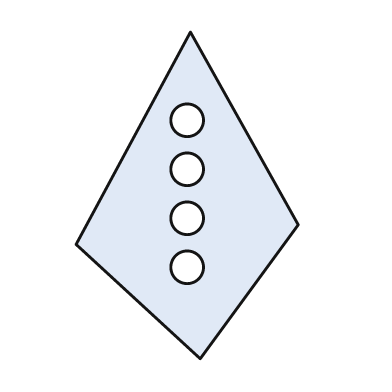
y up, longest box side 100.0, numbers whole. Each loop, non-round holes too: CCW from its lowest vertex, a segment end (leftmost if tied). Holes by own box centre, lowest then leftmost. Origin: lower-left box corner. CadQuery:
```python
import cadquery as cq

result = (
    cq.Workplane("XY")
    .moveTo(38.0, 0.0)
    .lineTo(68.0, 41.0)
    .lineTo(35.0, 100.0)
    .lineTo(0.0, 35.0)
    .close()
    .moveTo(34.0, 28.0)
    .circle(5.0)
    .moveTo(34.0, 43.0)
    .circle(5.0)
    .moveTo(34.0, 58.0)
    .circle(5.0)
    .moveTo(34.0, 73.0)
    .circle(5.0)
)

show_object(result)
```